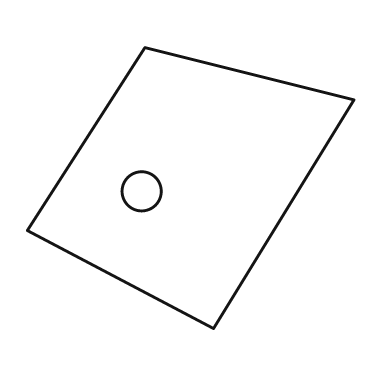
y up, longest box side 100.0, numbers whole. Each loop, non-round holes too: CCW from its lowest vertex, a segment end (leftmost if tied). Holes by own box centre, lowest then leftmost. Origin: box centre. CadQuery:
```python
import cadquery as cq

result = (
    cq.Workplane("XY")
    .moveTo(7.0, -43.0)
    .lineTo(50.0, 27.0)
    .lineTo(-14.0, 43.0)
    .lineTo(-50.0, -13.0)
    .close()
    .moveTo(-15.0, -1.0)
    .circle(6.0)
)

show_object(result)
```